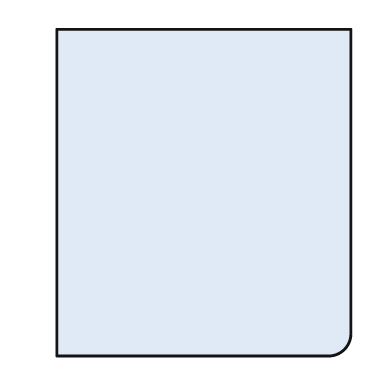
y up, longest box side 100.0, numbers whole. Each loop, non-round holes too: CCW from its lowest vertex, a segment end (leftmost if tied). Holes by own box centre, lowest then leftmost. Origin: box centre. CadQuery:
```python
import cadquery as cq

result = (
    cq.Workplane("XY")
    .moveTo(-45.0, -50.0)
    .lineTo(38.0, -50.0)
    .threePointArc((43.0, -48.0), (45.0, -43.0))
    .lineTo(45.0, 50.0)
    .lineTo(-45.0, 50.0)
    .close()
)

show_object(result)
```